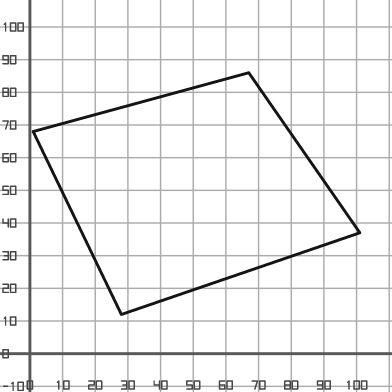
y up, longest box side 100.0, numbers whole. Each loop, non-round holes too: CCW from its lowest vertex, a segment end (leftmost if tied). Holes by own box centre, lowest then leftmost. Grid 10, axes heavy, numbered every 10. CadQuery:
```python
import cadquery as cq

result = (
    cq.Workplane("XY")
    .moveTo(28.0, 12.0)
    .lineTo(101.0, 37.0)
    .lineTo(67.0, 86.0)
    .lineTo(1.0, 68.0)
    .close()
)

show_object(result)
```